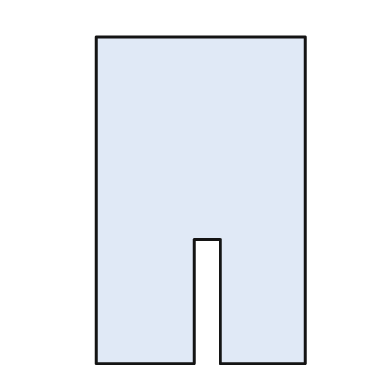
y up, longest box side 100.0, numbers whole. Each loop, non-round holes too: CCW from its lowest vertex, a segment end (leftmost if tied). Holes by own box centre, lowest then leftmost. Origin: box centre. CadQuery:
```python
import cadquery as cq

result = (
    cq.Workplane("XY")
    .moveTo(-32.0, -50.0)
    .lineTo(-2.0, -50.0)
    .lineTo(-2.0, -12.0)
    .lineTo(6.0, -12.0)
    .lineTo(6.0, -50.0)
    .lineTo(32.0, -50.0)
    .lineTo(32.0, 50.0)
    .lineTo(-32.0, 50.0)
    .close()
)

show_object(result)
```